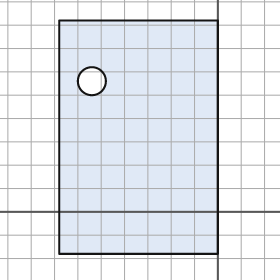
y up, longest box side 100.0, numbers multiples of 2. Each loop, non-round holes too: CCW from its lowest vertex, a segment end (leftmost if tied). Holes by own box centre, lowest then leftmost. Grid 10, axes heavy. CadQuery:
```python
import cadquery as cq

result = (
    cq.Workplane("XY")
    .moveTo(-68.0, -18.0)
    .lineTo(0.0, -18.0)
    .lineTo(0.0, 82.0)
    .lineTo(-68.0, 82.0)
    .close()
    .moveTo(-54.0, 56.0)
    .circle(6.0)
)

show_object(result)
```